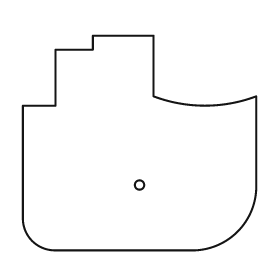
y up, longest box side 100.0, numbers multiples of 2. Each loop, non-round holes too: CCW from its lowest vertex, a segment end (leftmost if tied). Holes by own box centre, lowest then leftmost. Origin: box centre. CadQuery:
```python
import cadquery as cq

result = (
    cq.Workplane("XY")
    .moveTo(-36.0, -46.0)
    .lineTo(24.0, -46.0)
    .threePointArc((42.0, -38.0), (50.0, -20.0))
    .lineTo(50.0, 20.0)
    .threePointArc((28.0, 16.0), (6.0, 20.0))
    .lineTo(6.0, 46.0)
    .lineTo(-20.0, 46.0)
    .lineTo(-20.0, 40.0)
    .lineTo(-36.0, 40.0)
    .lineTo(-36.0, 16.0)
    .lineTo(-50.0, 16.0)
    .lineTo(-50.0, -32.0)
    .threePointArc((-46.0, -42.0), (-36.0, -46.0))
    .close()
    .moveTo(0.0, -18.0)
    .circle(2.0)
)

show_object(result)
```